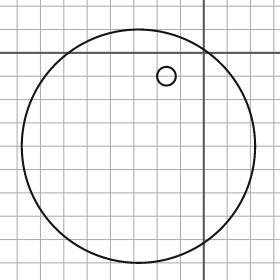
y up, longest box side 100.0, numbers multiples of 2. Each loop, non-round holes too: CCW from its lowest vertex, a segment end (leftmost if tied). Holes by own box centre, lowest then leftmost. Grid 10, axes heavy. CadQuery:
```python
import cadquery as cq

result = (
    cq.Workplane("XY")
    .moveTo(-28.0, -40.0)
    .circle(50.0)
    .moveTo(-16.0, -10.0)
    .circle(4.0)
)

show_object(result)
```